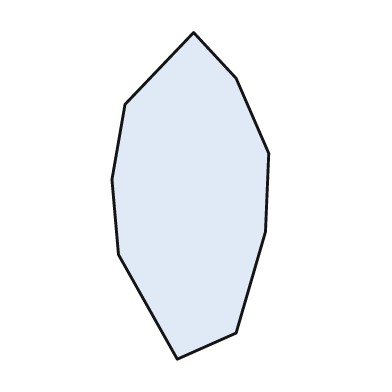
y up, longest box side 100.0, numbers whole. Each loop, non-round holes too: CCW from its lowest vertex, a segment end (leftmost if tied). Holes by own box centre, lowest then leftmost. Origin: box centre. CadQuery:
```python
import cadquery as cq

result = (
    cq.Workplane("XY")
    .moveTo(-4.0, -50.0)
    .lineTo(14.0, -42.0)
    .lineTo(23.0, -11.0)
    .lineTo(24.0, 13.0)
    .lineTo(14.0, 36.0)
    .lineTo(1.0, 50.0)
    .lineTo(-20.0, 28.0)
    .lineTo(-24.0, 5.0)
    .lineTo(-22.0, -18.0)
    .close()
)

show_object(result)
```